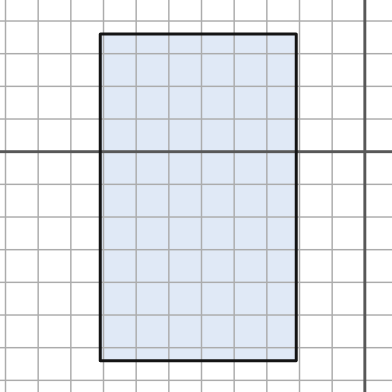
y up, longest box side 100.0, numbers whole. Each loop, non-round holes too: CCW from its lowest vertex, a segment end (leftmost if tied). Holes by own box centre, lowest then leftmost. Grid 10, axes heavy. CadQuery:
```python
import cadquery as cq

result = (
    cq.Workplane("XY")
    .moveTo(-81.0, -64.0)
    .lineTo(-21.0, -64.0)
    .lineTo(-21.0, 36.0)
    .lineTo(-81.0, 36.0)
    .close()
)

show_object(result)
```